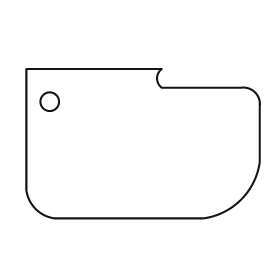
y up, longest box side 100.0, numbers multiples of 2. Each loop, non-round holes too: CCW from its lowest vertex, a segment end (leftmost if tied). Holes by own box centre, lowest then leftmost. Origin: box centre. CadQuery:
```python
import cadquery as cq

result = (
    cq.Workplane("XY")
    .moveTo(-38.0, -32.0)
    .lineTo(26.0, -32.0)
    .threePointArc((42.0, -24.0), (50.0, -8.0))
    .lineTo(50.0, 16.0)
    .threePointArc((48.0, 22.0), (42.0, 24.0))
    .lineTo(8.0, 24.0)
    .threePointArc((6.0, 28.0), (8.0, 32.0))
    .lineTo(-50.0, 32.0)
    .lineTo(-50.0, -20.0)
    .threePointArc((-46.0, -28.0), (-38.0, -32.0))
    .close()
    .moveTo(-40.0, 18.0)
    .circle(4.0)
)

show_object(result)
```